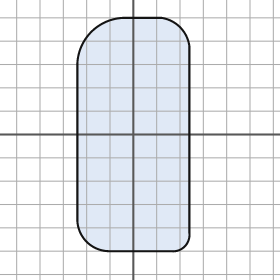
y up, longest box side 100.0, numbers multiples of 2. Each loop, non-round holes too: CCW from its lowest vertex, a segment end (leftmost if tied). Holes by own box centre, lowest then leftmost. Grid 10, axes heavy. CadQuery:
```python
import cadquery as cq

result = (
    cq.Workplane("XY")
    .moveTo(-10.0, -50.0)
    .lineTo(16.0, -50.0)
    .threePointArc((22.0, -48.0), (24.0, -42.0))
    .lineTo(24.0, 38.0)
    .threePointArc((20.0, 46.0), (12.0, 50.0))
    .lineTo(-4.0, 50.0)
    .threePointArc((-18.0, 44.0), (-24.0, 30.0))
    .lineTo(-24.0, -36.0)
    .threePointArc((-20.0, -46.0), (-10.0, -50.0))
    .close()
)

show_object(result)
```